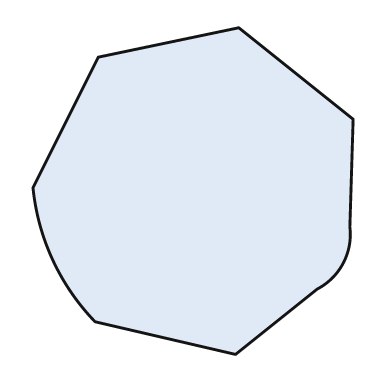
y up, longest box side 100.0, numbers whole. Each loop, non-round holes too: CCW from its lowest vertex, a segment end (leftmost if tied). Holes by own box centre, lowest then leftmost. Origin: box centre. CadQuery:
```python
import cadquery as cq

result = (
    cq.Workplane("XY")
    .moveTo(13.0, -50.0)
    .lineTo(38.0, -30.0)
    .threePointArc((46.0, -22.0), (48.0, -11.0))
    .lineTo(49.0, 22.0)
    .lineTo(14.0, 50.0)
    .lineTo(-29.0, 41.0)
    .lineTo(-49.0, 1.0)
    .threePointArc((-43.0, -21.0), (-30.0, -40.0))
    .close()
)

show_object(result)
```